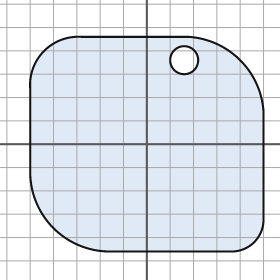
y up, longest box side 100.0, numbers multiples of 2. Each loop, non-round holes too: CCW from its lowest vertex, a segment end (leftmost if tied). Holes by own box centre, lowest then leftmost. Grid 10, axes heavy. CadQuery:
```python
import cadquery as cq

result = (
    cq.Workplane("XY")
    .moveTo(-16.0, -46.0)
    .lineTo(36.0, -46.0)
    .threePointArc((46.0, -42.0), (50.0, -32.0))
    .lineTo(50.0, 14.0)
    .threePointArc((40.0, 36.0), (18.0, 46.0))
    .lineTo(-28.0, 46.0)
    .threePointArc((-44.0, 40.0), (-50.0, 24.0))
    .lineTo(-50.0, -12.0)
    .threePointArc((-40.0, -36.0), (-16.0, -46.0))
    .close()
    .moveTo(16.0, 36.0)
    .circle(6.0)
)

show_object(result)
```